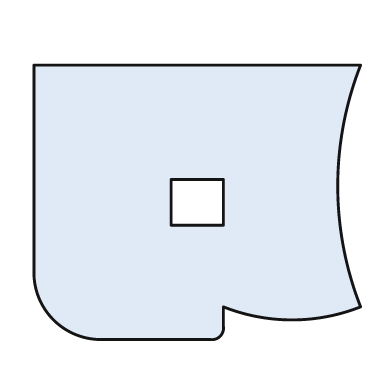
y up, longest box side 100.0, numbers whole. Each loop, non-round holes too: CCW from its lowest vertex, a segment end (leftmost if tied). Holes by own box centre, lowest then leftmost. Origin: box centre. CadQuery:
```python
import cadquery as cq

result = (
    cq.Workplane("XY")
    .moveTo(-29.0, -42.0)
    .lineTo(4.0, -42.0)
    .threePointArc((7.0, -41.0), (8.0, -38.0))
    .lineTo(8.0, -32.0)
    .threePointArc((29.0, -36.0), (50.0, -32.0))
    .threePointArc((43.0, 5.0), (50.0, 42.0))
    .lineTo(-50.0, 42.0)
    .lineTo(-50.0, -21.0)
    .threePointArc((-44.0, -36.0), (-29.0, -42.0))
    .close()
    .moveTo(-8.0, -7.0)
    .lineTo(8.0, -7.0)
    .lineTo(8.0, 7.0)
    .lineTo(-8.0, 7.0)
    .close()
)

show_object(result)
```